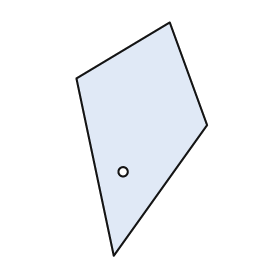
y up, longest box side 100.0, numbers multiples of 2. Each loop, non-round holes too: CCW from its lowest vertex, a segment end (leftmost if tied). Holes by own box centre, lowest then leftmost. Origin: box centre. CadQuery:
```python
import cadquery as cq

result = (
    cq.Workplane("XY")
    .moveTo(-12.0, -50.0)
    .lineTo(28.0, 6.0)
    .lineTo(12.0, 50.0)
    .lineTo(-28.0, 26.0)
    .close()
    .moveTo(-8.0, -14.0)
    .circle(2.0)
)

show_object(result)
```